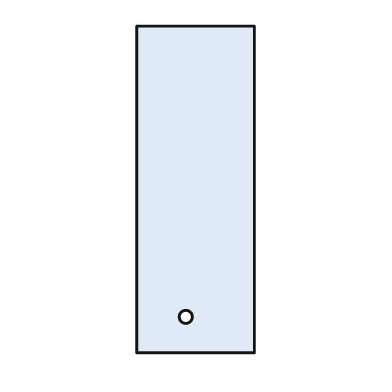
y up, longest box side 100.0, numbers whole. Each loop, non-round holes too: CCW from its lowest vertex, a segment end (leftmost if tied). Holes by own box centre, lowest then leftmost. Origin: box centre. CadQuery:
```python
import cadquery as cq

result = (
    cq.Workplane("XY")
    .moveTo(-18.0, -50.0)
    .lineTo(18.0, -50.0)
    .lineTo(18.0, 50.0)
    .lineTo(-18.0, 50.0)
    .close()
    .moveTo(-3.0, -39.0)
    .circle(2.0)
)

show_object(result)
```